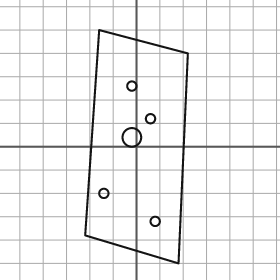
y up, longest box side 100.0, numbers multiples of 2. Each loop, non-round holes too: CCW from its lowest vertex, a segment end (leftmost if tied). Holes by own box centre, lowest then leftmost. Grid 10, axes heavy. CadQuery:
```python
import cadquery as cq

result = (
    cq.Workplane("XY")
    .moveTo(18.0, -50.0)
    .lineTo(22.0, 40.0)
    .lineTo(-16.0, 50.0)
    .lineTo(-22.0, -38.0)
    .close()
    .moveTo(8.0, -32.0)
    .circle(2.0)
    .moveTo(-14.0, -20.0)
    .circle(2.0)
    .moveTo(-2.0, 4.0)
    .circle(4.0)
    .moveTo(6.0, 12.0)
    .circle(2.0)
    .moveTo(-2.0, 26.0)
    .circle(2.0)
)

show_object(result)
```